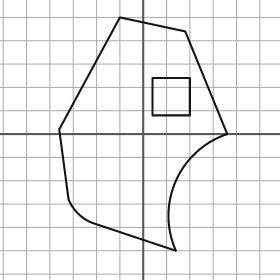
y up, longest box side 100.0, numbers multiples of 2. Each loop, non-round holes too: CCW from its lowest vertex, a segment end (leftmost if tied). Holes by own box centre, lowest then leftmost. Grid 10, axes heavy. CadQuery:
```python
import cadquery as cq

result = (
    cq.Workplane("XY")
    .moveTo(14.0, -50.0)
    .threePointArc((14.0, -20.0), (36.0, 0.0))
    .lineTo(18.0, 44.0)
    .lineTo(-10.0, 50.0)
    .lineTo(-36.0, 2.0)
    .lineTo(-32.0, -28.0)
    .threePointArc((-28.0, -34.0), (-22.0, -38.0))
    .close()
    .moveTo(4.0, 8.0)
    .lineTo(20.0, 8.0)
    .lineTo(20.0, 24.0)
    .lineTo(4.0, 24.0)
    .close()
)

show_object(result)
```